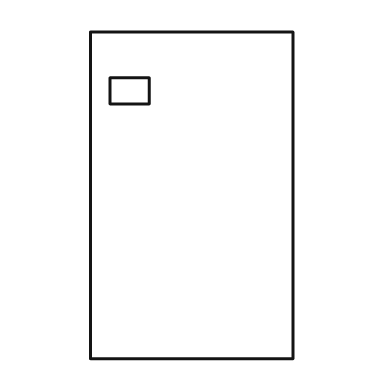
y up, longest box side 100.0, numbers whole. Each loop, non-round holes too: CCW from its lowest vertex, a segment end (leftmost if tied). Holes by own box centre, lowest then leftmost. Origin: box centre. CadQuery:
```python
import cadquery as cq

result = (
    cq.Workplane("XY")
    .moveTo(-31.0, -50.0)
    .lineTo(31.0, -50.0)
    .lineTo(31.0, 50.0)
    .lineTo(-31.0, 50.0)
    .close()
    .moveTo(-25.0, 28.0)
    .lineTo(-13.0, 28.0)
    .lineTo(-13.0, 36.0)
    .lineTo(-25.0, 36.0)
    .close()
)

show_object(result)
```